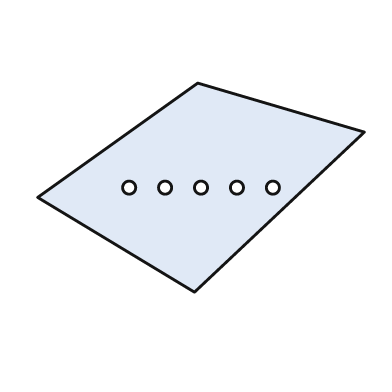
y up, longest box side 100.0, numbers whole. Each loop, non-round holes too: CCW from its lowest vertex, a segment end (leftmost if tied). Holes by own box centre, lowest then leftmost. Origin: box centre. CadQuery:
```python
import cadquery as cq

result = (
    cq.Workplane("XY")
    .moveTo(-2.0, -32.0)
    .lineTo(50.0, 17.0)
    .lineTo(-1.0, 32.0)
    .lineTo(-50.0, -3.0)
    .close()
    .moveTo(-22.0, 0.0)
    .circle(2.0)
    .moveTo(-11.0, 0.0)
    .circle(2.0)
    .moveTo(0.0, 0.0)
    .circle(2.0)
    .moveTo(11.0, 0.0)
    .circle(2.0)
    .moveTo(22.0, 0.0)
    .circle(2.0)
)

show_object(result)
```